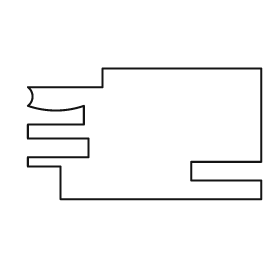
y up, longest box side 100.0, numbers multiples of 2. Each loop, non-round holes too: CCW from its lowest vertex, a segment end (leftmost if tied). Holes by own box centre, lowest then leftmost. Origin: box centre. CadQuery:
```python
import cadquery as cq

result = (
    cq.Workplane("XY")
    .moveTo(-36.0, -28.0)
    .lineTo(50.0, -28.0)
    .lineTo(50.0, -20.0)
    .lineTo(20.0, -20.0)
    .lineTo(20.0, -12.0)
    .lineTo(50.0, -12.0)
    .lineTo(50.0, 28.0)
    .lineTo(-18.0, 28.0)
    .lineTo(-18.0, 20.0)
    .lineTo(-50.0, 20.0)
    .threePointArc((-48.0, 16.0), (-50.0, 12.0))
    .threePointArc((-38.0, 10.0), (-26.0, 12.0))
    .lineTo(-26.0, 4.0)
    .lineTo(-50.0, 4.0)
    .lineTo(-50.0, -2.0)
    .lineTo(-24.0, -2.0)
    .lineTo(-24.0, -10.0)
    .lineTo(-50.0, -10.0)
    .lineTo(-50.0, -14.0)
    .lineTo(-36.0, -14.0)
    .close()
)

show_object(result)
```